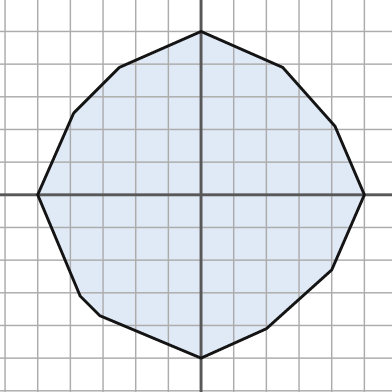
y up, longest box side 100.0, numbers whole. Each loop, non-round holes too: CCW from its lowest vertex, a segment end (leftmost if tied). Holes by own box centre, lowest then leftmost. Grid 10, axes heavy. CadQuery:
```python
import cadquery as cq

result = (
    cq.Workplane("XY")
    .moveTo(0.0, -50.0)
    .lineTo(20.0, -41.0)
    .lineTo(40.0, -23.0)
    .lineTo(50.0, 0.0)
    .lineTo(41.0, 21.0)
    .lineTo(25.0, 39.0)
    .lineTo(0.0, 50.0)
    .lineTo(-25.0, 39.0)
    .lineTo(-39.0, 25.0)
    .lineTo(-50.0, 0.0)
    .lineTo(-37.0, -31.0)
    .lineTo(-31.0, -37.0)
    .close()
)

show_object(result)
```